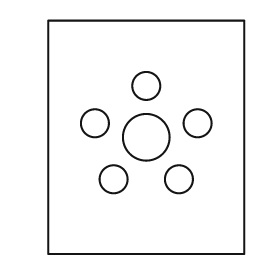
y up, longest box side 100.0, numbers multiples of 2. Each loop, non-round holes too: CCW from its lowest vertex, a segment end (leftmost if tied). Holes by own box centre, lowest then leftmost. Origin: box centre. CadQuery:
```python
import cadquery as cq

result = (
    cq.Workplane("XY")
    .moveTo(-42.0, -50.0)
    .lineTo(42.0, -50.0)
    .lineTo(42.0, 50.0)
    .lineTo(-42.0, 50.0)
    .close()
    .moveTo(-14.0, -18.0)
    .circle(6.0)
    .moveTo(14.0, -18.0)
    .circle(6.0)
    .moveTo(0.0, 0.0)
    .circle(10.0)
    .moveTo(-22.0, 6.0)
    .circle(6.0)
    .moveTo(22.0, 6.0)
    .circle(6.0)
    .moveTo(0.0, 22.0)
    .circle(6.0)
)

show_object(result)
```